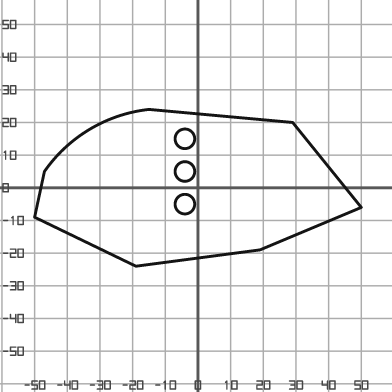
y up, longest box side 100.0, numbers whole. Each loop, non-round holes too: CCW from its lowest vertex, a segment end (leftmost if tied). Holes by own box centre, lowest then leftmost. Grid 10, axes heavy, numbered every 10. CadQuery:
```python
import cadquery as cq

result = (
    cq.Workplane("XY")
    .moveTo(-19.0, -24.0)
    .lineTo(19.0, -19.0)
    .lineTo(50.0, -6.0)
    .lineTo(29.0, 20.0)
    .lineTo(-15.0, 24.0)
    .threePointArc((-33.0, 18.0), (-47.0, 5.0))
    .lineTo(-50.0, -9.0)
    .close()
    .moveTo(-4.0, -5.0)
    .circle(3.0)
    .moveTo(-4.0, 5.0)
    .circle(3.0)
    .moveTo(-4.0, 15.0)
    .circle(3.0)
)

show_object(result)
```